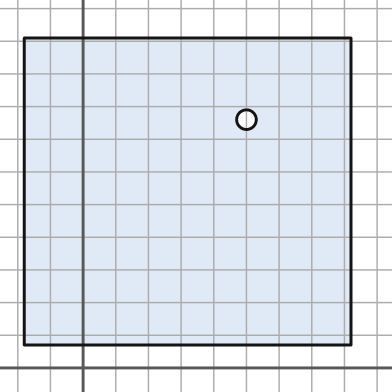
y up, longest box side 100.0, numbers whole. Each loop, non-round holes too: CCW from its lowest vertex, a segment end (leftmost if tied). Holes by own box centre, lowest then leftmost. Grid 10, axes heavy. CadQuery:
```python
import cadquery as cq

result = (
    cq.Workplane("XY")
    .moveTo(-18.0, 7.0)
    .lineTo(82.0, 7.0)
    .lineTo(82.0, 101.0)
    .lineTo(-18.0, 101.0)
    .close()
    .moveTo(50.0, 76.0)
    .circle(3.0)
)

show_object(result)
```